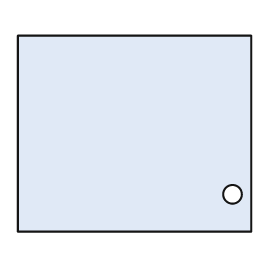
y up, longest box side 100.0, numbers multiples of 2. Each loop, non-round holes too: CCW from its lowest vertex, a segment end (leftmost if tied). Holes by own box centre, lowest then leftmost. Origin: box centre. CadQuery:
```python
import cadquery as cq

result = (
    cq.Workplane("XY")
    .moveTo(-50.0, -42.0)
    .lineTo(50.0, -42.0)
    .lineTo(50.0, 42.0)
    .lineTo(-50.0, 42.0)
    .close()
    .moveTo(42.0, -26.0)
    .circle(4.0)
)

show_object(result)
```